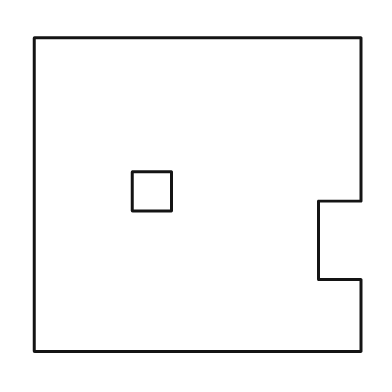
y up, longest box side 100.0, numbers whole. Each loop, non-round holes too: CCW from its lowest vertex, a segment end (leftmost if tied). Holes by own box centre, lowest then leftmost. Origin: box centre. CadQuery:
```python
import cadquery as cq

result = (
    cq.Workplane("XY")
    .moveTo(-50.0, -48.0)
    .lineTo(50.0, -48.0)
    .lineTo(50.0, -26.0)
    .lineTo(37.0, -26.0)
    .lineTo(37.0, -2.0)
    .lineTo(50.0, -2.0)
    .lineTo(50.0, 48.0)
    .lineTo(-50.0, 48.0)
    .close()
    .moveTo(-20.0, -5.0)
    .lineTo(-8.0, -5.0)
    .lineTo(-8.0, 7.0)
    .lineTo(-20.0, 7.0)
    .close()
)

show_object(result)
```